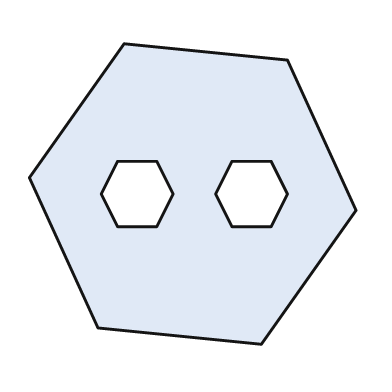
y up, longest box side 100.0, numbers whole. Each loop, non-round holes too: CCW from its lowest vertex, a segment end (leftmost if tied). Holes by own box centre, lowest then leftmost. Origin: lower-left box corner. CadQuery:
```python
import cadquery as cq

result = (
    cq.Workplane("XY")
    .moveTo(71.0, 0.0)
    .lineTo(100.0, 41.0)
    .lineTo(79.0, 87.0)
    .lineTo(29.0, 92.0)
    .lineTo(0.0, 51.0)
    .lineTo(21.0, 5.0)
    .close()
    .moveTo(27.0, 36.0)
    .lineTo(39.0, 36.0)
    .lineTo(44.0, 46.0)
    .lineTo(39.0, 56.0)
    .lineTo(27.0, 56.0)
    .lineTo(22.0, 46.0)
    .close()
    .moveTo(62.0, 36.0)
    .lineTo(74.0, 36.0)
    .lineTo(79.0, 46.0)
    .lineTo(74.0, 56.0)
    .lineTo(62.0, 56.0)
    .lineTo(57.0, 46.0)
    .close()
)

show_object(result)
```